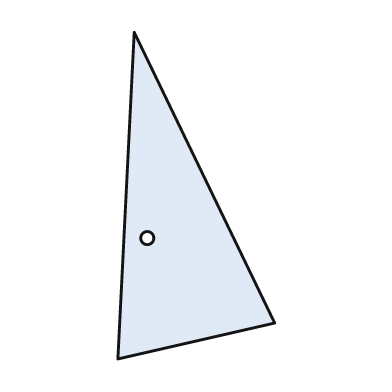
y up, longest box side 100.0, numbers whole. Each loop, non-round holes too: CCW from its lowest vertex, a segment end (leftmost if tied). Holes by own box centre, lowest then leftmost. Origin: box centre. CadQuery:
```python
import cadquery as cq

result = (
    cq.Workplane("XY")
    .moveTo(-24.0, -50.0)
    .lineTo(24.0, -39.0)
    .lineTo(-19.0, 50.0)
    .close()
    .moveTo(-15.0, -13.0)
    .circle(2.0)
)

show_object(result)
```